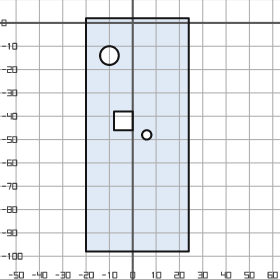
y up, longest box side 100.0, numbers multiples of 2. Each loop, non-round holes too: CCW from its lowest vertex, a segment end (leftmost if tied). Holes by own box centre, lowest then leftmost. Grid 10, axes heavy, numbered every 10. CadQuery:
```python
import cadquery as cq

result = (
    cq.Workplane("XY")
    .moveTo(-20.0, -98.0)
    .lineTo(24.0, -98.0)
    .lineTo(24.0, 2.0)
    .lineTo(-20.0, 2.0)
    .close()
    .moveTo(6.0, -48.0)
    .circle(2.0)
    .moveTo(-8.0, -46.0)
    .lineTo(0.0, -46.0)
    .lineTo(0.0, -38.0)
    .lineTo(-8.0, -38.0)
    .close()
    .moveTo(-10.0, -14.0)
    .circle(4.0)
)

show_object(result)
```